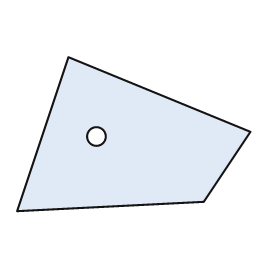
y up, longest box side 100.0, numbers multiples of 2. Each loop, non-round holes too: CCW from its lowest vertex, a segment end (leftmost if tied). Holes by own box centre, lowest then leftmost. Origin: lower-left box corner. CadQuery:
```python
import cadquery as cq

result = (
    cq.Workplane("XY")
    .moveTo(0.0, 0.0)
    .lineTo(80.0, 4.0)
    .lineTo(100.0, 34.0)
    .lineTo(22.0, 66.0)
    .close()
    .moveTo(34.0, 32.0)
    .circle(4.0)
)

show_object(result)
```